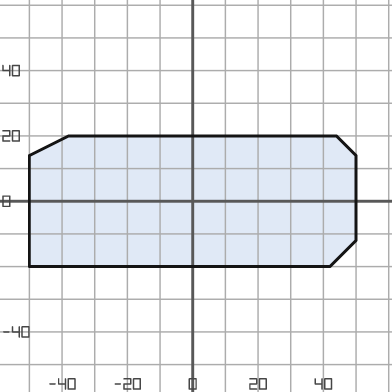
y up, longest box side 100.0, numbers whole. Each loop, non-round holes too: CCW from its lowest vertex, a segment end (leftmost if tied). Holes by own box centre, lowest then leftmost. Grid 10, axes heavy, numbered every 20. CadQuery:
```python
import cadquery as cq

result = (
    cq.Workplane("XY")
    .moveTo(-50.0, -20.0)
    .lineTo(42.0, -20.0)
    .lineTo(50.0, -12.0)
    .lineTo(50.0, 14.0)
    .lineTo(44.0, 20.0)
    .lineTo(-38.0, 20.0)
    .lineTo(-50.0, 14.0)
    .close()
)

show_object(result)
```